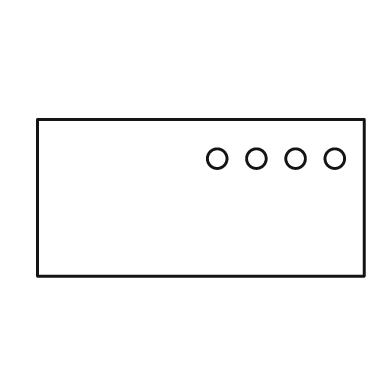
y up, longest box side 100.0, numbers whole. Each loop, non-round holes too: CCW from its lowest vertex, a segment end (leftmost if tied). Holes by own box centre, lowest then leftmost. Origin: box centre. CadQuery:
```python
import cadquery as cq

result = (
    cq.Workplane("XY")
    .moveTo(-50.0, -24.0)
    .lineTo(50.0, -24.0)
    .lineTo(50.0, 24.0)
    .lineTo(-50.0, 24.0)
    .close()
    .moveTo(5.0, 12.0)
    .circle(3.0)
    .moveTo(17.0, 12.0)
    .circle(3.0)
    .moveTo(29.0, 12.0)
    .circle(3.0)
    .moveTo(41.0, 12.0)
    .circle(3.0)
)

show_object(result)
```